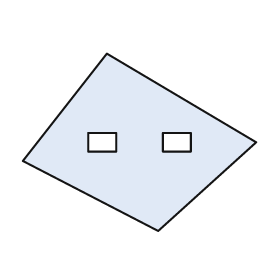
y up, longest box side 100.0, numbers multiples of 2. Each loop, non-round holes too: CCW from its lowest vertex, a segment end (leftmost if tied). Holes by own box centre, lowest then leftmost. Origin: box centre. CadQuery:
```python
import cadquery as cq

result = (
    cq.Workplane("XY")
    .moveTo(8.0, -38.0)
    .lineTo(50.0, 0.0)
    .lineTo(-14.0, 38.0)
    .lineTo(-50.0, -8.0)
    .close()
    .moveTo(-22.0, -4.0)
    .lineTo(-10.0, -4.0)
    .lineTo(-10.0, 4.0)
    .lineTo(-22.0, 4.0)
    .close()
    .moveTo(10.0, -4.0)
    .lineTo(22.0, -4.0)
    .lineTo(22.0, 4.0)
    .lineTo(10.0, 4.0)
    .close()
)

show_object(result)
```